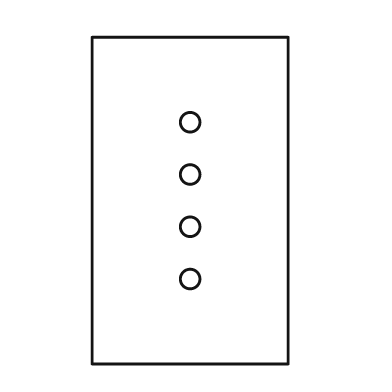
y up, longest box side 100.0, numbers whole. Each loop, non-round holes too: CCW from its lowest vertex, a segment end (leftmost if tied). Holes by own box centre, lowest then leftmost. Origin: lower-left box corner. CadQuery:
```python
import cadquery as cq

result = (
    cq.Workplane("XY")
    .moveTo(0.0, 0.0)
    .lineTo(60.0, 0.0)
    .lineTo(60.0, 100.0)
    .lineTo(0.0, 100.0)
    .close()
    .moveTo(30.0, 26.0)
    .circle(3.0)
    .moveTo(30.0, 42.0)
    .circle(3.0)
    .moveTo(30.0, 58.0)
    .circle(3.0)
    .moveTo(30.0, 74.0)
    .circle(3.0)
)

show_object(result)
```